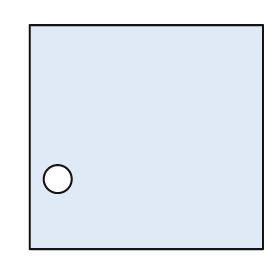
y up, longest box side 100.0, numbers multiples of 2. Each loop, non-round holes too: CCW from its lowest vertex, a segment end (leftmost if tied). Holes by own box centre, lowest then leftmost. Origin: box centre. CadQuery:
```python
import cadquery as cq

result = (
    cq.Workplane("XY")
    .moveTo(-50.0, -48.0)
    .lineTo(50.0, -48.0)
    .lineTo(50.0, 48.0)
    .lineTo(-50.0, 48.0)
    .close()
    .moveTo(-38.0, -18.0)
    .circle(6.0)
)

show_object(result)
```